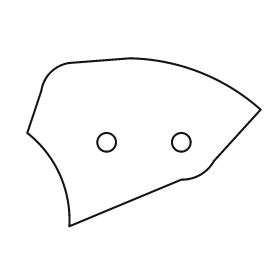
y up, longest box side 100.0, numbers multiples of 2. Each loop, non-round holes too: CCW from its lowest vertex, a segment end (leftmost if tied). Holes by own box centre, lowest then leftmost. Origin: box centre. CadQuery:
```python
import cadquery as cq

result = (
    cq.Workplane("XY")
    .moveTo(-32.0, -36.0)
    .lineTo(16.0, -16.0)
    .threePointArc((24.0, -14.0), (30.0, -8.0))
    .lineTo(50.0, 14.0)
    .threePointArc((24.0, 30.0), (-6.0, 36.0))
    .lineTo(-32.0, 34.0)
    .threePointArc((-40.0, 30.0), (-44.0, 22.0))
    .lineTo(-50.0, 4.0)
    .threePointArc((-36.0, -14.0), (-32.0, -36.0))
    .close()
    .moveTo(-16.0, 0.0)
    .circle(4.0)
    .moveTo(16.0, 0.0)
    .circle(4.0)
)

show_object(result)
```